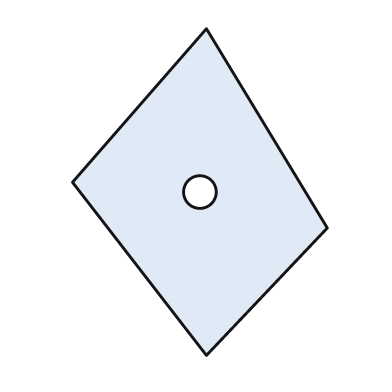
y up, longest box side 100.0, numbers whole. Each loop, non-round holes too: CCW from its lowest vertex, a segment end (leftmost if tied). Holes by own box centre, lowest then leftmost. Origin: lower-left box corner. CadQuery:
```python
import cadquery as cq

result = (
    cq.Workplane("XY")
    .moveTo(41.0, 0.0)
    .lineTo(78.0, 39.0)
    .lineTo(41.0, 100.0)
    .lineTo(0.0, 53.0)
    .close()
    .moveTo(39.0, 50.0)
    .circle(5.0)
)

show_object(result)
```